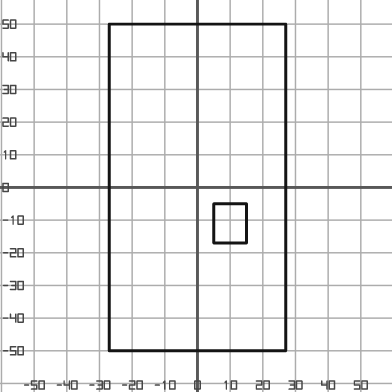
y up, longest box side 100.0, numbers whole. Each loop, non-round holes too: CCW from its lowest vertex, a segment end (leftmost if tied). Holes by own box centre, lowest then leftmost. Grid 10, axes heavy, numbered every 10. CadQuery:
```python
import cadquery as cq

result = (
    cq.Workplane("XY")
    .moveTo(-27.0, -50.0)
    .lineTo(27.0, -50.0)
    .lineTo(27.0, 50.0)
    .lineTo(-27.0, 50.0)
    .close()
    .moveTo(5.0, -17.0)
    .lineTo(15.0, -17.0)
    .lineTo(15.0, -5.0)
    .lineTo(5.0, -5.0)
    .close()
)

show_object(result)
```